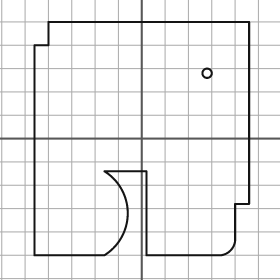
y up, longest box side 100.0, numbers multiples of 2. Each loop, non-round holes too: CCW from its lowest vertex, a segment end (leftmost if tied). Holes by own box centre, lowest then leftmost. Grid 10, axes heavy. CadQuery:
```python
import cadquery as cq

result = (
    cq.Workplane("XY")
    .moveTo(-46.0, -50.0)
    .lineTo(-16.0, -50.0)
    .threePointArc((-6.0, -32.0), (-16.0, -14.0))
    .lineTo(2.0, -14.0)
    .lineTo(2.0, -50.0)
    .lineTo(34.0, -50.0)
    .threePointArc((38.0, -48.0), (40.0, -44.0))
    .lineTo(40.0, -28.0)
    .lineTo(46.0, -28.0)
    .lineTo(46.0, 50.0)
    .lineTo(-40.0, 50.0)
    .lineTo(-40.0, 40.0)
    .lineTo(-46.0, 40.0)
    .close()
    .moveTo(28.0, 28.0)
    .circle(2.0)
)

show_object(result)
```